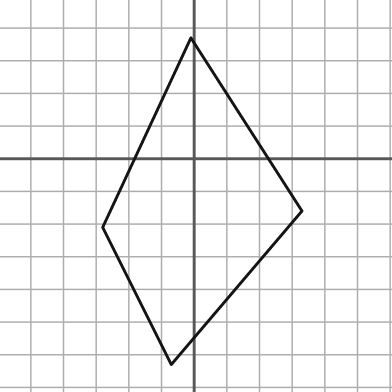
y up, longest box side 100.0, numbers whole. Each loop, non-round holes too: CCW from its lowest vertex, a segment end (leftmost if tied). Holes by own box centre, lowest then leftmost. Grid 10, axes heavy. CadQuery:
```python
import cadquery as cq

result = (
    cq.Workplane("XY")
    .moveTo(-7.0, -63.0)
    .lineTo(33.0, -16.0)
    .lineTo(-1.0, 37.0)
    .lineTo(-28.0, -21.0)
    .close()
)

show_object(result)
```